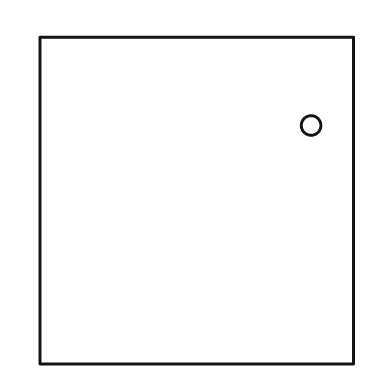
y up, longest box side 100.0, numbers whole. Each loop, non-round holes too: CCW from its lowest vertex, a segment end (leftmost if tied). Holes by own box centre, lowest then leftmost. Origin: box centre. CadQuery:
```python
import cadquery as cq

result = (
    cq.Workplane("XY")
    .moveTo(-48.0, -50.0)
    .lineTo(48.0, -50.0)
    .lineTo(48.0, 50.0)
    .lineTo(-48.0, 50.0)
    .close()
    .moveTo(35.0, 23.0)
    .circle(3.0)
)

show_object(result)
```